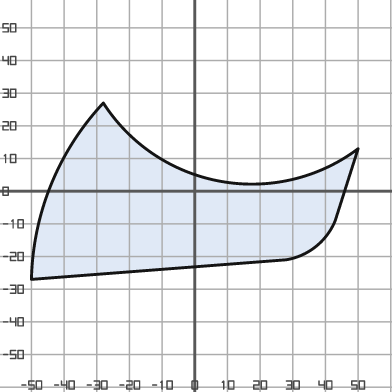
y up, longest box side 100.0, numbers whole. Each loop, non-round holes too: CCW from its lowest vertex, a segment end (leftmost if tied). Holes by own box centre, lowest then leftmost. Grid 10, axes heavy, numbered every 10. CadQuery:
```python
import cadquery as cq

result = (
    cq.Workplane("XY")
    .moveTo(-50.0, -27.0)
    .lineTo(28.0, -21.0)
    .threePointArc((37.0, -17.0), (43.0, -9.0))
    .lineTo(50.0, 13.0)
    .threePointArc((8.0, 3.0), (-28.0, 27.0))
    .threePointArc((-44.0, 2.0), (-50.0, -27.0))
    .close()
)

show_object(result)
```